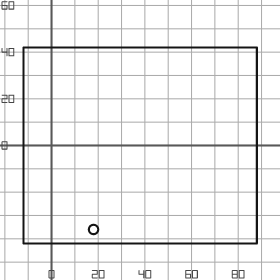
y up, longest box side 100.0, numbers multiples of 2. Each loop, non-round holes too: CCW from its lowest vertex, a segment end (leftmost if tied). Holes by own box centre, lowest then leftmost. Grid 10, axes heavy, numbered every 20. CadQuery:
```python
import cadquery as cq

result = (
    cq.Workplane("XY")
    .moveTo(-12.0, -42.0)
    .lineTo(88.0, -42.0)
    .lineTo(88.0, 42.0)
    .lineTo(-12.0, 42.0)
    .close()
    .moveTo(18.0, -36.0)
    .circle(2.0)
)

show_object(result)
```